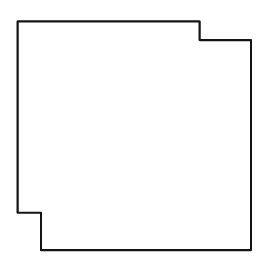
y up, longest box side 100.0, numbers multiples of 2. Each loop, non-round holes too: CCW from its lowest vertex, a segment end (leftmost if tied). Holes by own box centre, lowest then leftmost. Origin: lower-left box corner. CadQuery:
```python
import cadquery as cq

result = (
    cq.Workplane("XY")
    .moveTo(10.0, 0.0)
    .lineTo(100.0, 0.0)
    .lineTo(100.0, 90.0)
    .lineTo(78.0, 90.0)
    .lineTo(78.0, 98.0)
    .lineTo(0.0, 98.0)
    .lineTo(0.0, 16.0)
    .lineTo(10.0, 16.0)
    .close()
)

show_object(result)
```